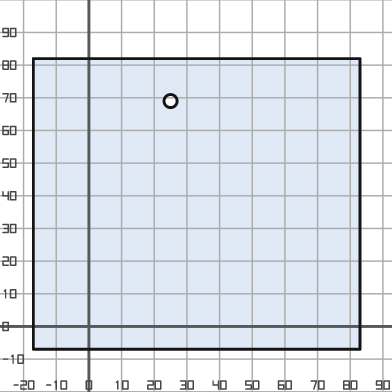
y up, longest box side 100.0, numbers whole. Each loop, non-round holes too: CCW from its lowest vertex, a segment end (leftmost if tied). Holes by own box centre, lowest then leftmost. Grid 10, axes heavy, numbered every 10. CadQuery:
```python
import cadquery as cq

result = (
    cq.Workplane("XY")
    .moveTo(-17.0, -7.0)
    .lineTo(83.0, -7.0)
    .lineTo(83.0, 82.0)
    .lineTo(-17.0, 82.0)
    .close()
    .moveTo(25.0, 69.0)
    .circle(2.0)
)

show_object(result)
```